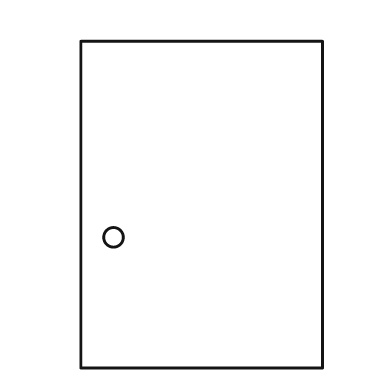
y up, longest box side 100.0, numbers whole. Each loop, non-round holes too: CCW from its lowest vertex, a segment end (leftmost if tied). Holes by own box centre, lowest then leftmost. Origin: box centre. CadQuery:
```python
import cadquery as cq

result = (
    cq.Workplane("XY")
    .moveTo(-37.0, -50.0)
    .lineTo(37.0, -50.0)
    .lineTo(37.0, 50.0)
    .lineTo(-37.0, 50.0)
    .close()
    .moveTo(-27.0, -10.0)
    .circle(3.0)
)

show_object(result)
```